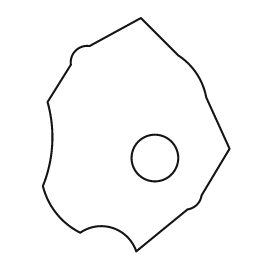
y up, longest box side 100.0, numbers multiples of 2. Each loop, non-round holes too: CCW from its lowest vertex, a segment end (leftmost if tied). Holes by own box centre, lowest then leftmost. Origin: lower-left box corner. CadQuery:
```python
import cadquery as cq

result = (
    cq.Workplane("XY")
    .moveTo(40.0, 0.0)
    .lineTo(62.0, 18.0)
    .threePointArc((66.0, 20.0), (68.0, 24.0))
    .lineTo(80.0, 44.0)
    .lineTo(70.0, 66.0)
    .threePointArc((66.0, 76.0), (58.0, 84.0))
    .lineTo(42.0, 100.0)
    .lineTo(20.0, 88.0)
    .threePointArc((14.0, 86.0), (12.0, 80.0))
    .lineTo(2.0, 64.0)
    .threePointArc((4.0, 46.0), (0.0, 28.0))
    .threePointArc((6.0, 16.0), (16.0, 8.0))
    .threePointArc((30.0, 10.0), (40.0, 0.0))
    .close()
    .moveTo(48.0, 40.0)
    .circle(10.0)
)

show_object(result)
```